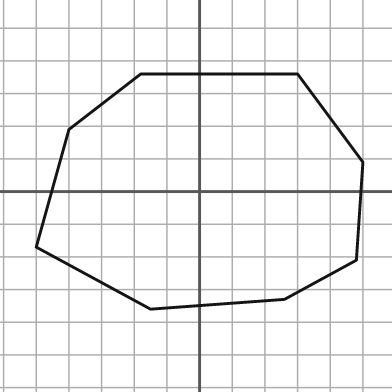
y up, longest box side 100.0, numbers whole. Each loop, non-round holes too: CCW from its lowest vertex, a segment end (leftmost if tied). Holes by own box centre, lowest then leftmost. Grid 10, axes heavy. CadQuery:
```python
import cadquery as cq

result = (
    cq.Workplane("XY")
    .moveTo(-15.0, -36.0)
    .lineTo(26.0, -33.0)
    .lineTo(48.0, -21.0)
    .lineTo(50.0, 9.0)
    .lineTo(30.0, 36.0)
    .lineTo(-18.0, 36.0)
    .lineTo(-40.0, 19.0)
    .lineTo(-50.0, -17.0)
    .close()
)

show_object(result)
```